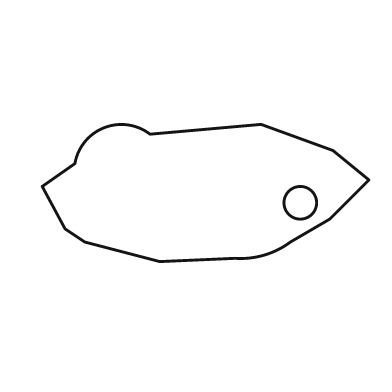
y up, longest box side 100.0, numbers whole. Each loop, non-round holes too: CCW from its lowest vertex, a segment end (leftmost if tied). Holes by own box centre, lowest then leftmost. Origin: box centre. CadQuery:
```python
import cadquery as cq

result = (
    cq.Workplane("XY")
    .moveTo(-14.0, -21.0)
    .lineTo(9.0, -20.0)
    .threePointArc((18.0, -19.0), (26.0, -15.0))
    .lineTo(38.0, -8.0)
    .lineTo(50.0, 4.0)
    .lineTo(39.0, 13.0)
    .lineTo(17.0, 21.0)
    .lineTo(-17.0, 18.0)
    .threePointArc((-31.0, 20.0), (-40.0, 9.0))
    .lineTo(-50.0, 2.0)
    .lineTo(-43.0, -11.0)
    .lineTo(-37.0, -15.0)
    .close()
    .moveTo(29.0, -3.0)
    .circle(5.0)
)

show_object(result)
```